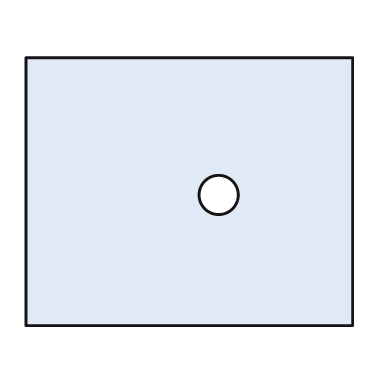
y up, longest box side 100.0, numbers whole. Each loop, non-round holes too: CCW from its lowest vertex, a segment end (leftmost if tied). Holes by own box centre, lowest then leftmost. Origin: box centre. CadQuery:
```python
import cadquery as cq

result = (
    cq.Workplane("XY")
    .moveTo(-50.0, -41.0)
    .lineTo(50.0, -41.0)
    .lineTo(50.0, 41.0)
    .lineTo(-50.0, 41.0)
    .close()
    .moveTo(9.0, -1.0)
    .circle(6.0)
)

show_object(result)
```